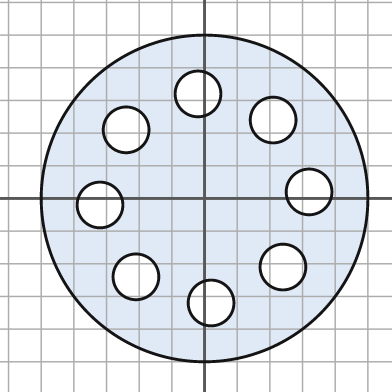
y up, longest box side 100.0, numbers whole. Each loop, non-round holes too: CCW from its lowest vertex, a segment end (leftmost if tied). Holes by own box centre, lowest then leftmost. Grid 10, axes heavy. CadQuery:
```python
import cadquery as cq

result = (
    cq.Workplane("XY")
    .moveTo(0.0, 0.0)
    .circle(50.0)
    .moveTo(2.0, -32.0)
    .circle(7.0)
    .moveTo(-21.0, -24.0)
    .circle(7.0)
    .moveTo(24.0, -21.0)
    .circle(7.0)
    .moveTo(-32.0, -2.0)
    .circle(7.0)
    .moveTo(32.0, 2.0)
    .circle(7.0)
    .moveTo(-24.0, 21.0)
    .circle(7.0)
    .moveTo(21.0, 24.0)
    .circle(7.0)
    .moveTo(-2.0, 32.0)
    .circle(7.0)
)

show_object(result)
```